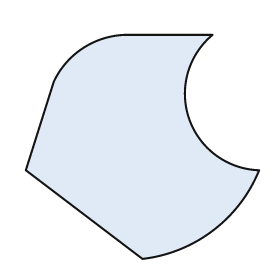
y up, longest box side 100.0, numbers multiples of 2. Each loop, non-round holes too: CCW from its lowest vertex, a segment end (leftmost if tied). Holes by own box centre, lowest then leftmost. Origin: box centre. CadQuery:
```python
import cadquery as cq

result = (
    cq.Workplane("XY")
    .moveTo(0.0, -48.0)
    .threePointArc((30.0, -36.0), (50.0, -10.0))
    .threePointArc((20.0, 12.0), (30.0, 48.0))
    .lineTo(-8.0, 48.0)
    .threePointArc((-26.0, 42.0), (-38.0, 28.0))
    .lineTo(-50.0, -10.0)
    .close()
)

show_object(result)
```